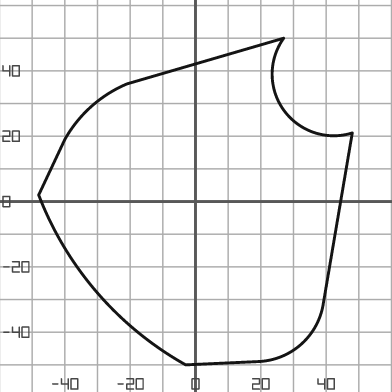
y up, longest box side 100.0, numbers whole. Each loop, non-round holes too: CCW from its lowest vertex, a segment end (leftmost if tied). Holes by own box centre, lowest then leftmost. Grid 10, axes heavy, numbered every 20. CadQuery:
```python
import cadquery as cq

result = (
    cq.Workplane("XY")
    .moveTo(-3.0, -50.0)
    .lineTo(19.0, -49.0)
    .threePointArc((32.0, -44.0), (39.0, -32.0))
    .lineTo(48.0, 21.0)
    .threePointArc((27.0, 28.0), (27.0, 50.0))
    .lineTo(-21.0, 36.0)
    .threePointArc((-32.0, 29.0), (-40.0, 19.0))
    .lineTo(-48.0, 2.0)
    .threePointArc((-30.0, -28.0), (-3.0, -50.0))
    .close()
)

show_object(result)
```